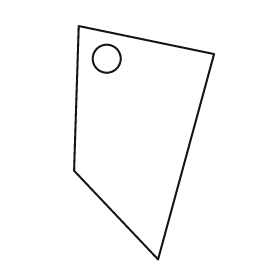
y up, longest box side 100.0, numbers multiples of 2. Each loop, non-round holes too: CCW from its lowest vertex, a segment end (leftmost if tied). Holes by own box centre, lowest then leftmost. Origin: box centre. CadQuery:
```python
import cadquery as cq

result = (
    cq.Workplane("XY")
    .moveTo(6.0, -50.0)
    .lineTo(30.0, 38.0)
    .lineTo(-28.0, 50.0)
    .lineTo(-30.0, -12.0)
    .close()
    .moveTo(-16.0, 36.0)
    .circle(6.0)
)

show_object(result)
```